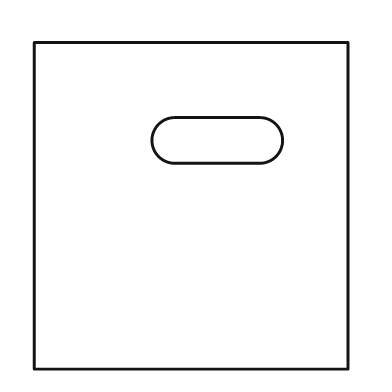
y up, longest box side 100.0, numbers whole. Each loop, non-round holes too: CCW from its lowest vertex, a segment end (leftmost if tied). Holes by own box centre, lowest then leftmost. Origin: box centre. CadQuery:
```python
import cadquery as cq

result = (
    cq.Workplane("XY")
    .moveTo(-48.0, -50.0)
    .lineTo(48.0, -50.0)
    .lineTo(48.0, 50.0)
    .lineTo(-48.0, 50.0)
    .close()
    .moveTo(-5.0, 13.0)
    .lineTo(21.0, 13.0)
    .threePointArc((28.0, 20.0), (21.0, 27.0))
    .lineTo(-5.0, 27.0)
    .threePointArc((-12.0, 20.0), (-5.0, 13.0))
    .close()
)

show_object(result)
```